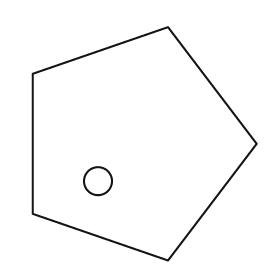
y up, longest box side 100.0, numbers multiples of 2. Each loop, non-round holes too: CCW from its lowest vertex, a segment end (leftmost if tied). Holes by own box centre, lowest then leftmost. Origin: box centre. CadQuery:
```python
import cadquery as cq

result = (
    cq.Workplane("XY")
    .moveTo(10.0, -50.0)
    .lineTo(48.0, 0.0)
    .lineTo(10.0, 50.0)
    .lineTo(-48.0, 30.0)
    .lineTo(-48.0, -30.0)
    .close()
    .moveTo(-20.0, -16.0)
    .circle(6.0)
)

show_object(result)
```